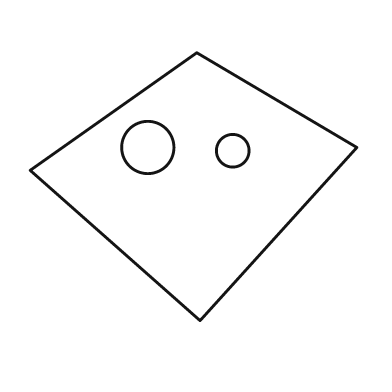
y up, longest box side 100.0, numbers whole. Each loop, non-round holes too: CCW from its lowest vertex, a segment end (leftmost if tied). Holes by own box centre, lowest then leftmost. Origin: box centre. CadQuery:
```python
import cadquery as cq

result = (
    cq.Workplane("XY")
    .moveTo(2.0, -41.0)
    .lineTo(50.0, 12.0)
    .lineTo(1.0, 41.0)
    .lineTo(-50.0, 5.0)
    .close()
    .moveTo(12.0, 11.0)
    .circle(5.0)
    .moveTo(-14.0, 12.0)
    .circle(8.0)
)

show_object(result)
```